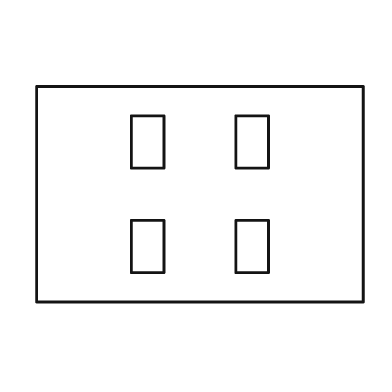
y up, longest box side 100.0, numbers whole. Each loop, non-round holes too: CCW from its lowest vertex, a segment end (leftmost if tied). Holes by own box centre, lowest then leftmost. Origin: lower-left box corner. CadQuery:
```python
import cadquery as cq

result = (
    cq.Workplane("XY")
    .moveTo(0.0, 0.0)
    .lineTo(100.0, 0.0)
    .lineTo(100.0, 66.0)
    .lineTo(0.0, 66.0)
    .close()
    .moveTo(29.0, 9.0)
    .lineTo(39.0, 9.0)
    .lineTo(39.0, 25.0)
    .lineTo(29.0, 25.0)
    .close()
    .moveTo(61.0, 9.0)
    .lineTo(71.0, 9.0)
    .lineTo(71.0, 25.0)
    .lineTo(61.0, 25.0)
    .close()
    .moveTo(29.0, 41.0)
    .lineTo(39.0, 41.0)
    .lineTo(39.0, 57.0)
    .lineTo(29.0, 57.0)
    .close()
    .moveTo(61.0, 41.0)
    .lineTo(71.0, 41.0)
    .lineTo(71.0, 57.0)
    .lineTo(61.0, 57.0)
    .close()
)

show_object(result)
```